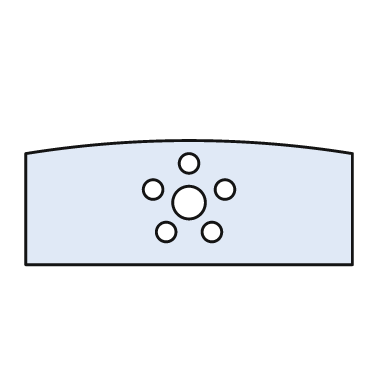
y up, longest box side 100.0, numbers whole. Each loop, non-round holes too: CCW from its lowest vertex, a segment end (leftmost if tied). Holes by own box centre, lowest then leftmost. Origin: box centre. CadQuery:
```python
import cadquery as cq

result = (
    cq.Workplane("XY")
    .moveTo(-50.0, -19.0)
    .lineTo(50.0, -19.0)
    .lineTo(50.0, 15.0)
    .threePointArc((0.0, 19.0), (-50.0, 15.0))
    .close()
    .moveTo(-7.0, -9.0)
    .circle(3.0)
    .moveTo(7.0, -9.0)
    .circle(3.0)
    .moveTo(0.0, 0.0)
    .circle(5.0)
    .moveTo(-11.0, 4.0)
    .circle(3.0)
    .moveTo(11.0, 4.0)
    .circle(3.0)
    .moveTo(0.0, 12.0)
    .circle(3.0)
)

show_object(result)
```